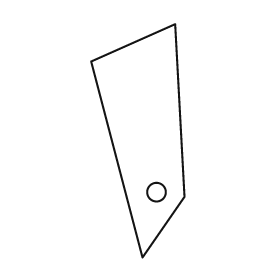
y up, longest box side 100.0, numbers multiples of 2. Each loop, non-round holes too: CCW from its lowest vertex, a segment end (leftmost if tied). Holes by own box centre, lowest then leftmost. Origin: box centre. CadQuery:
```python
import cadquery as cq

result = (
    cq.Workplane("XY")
    .moveTo(2.0, -50.0)
    .lineTo(20.0, -24.0)
    .lineTo(16.0, 50.0)
    .lineTo(-20.0, 34.0)
    .close()
    .moveTo(8.0, -22.0)
    .circle(4.0)
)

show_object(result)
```